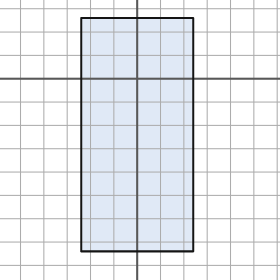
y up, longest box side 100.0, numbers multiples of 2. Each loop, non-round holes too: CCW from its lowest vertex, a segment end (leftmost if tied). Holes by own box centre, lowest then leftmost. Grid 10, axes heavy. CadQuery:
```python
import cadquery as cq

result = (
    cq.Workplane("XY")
    .moveTo(-24.0, -74.0)
    .lineTo(24.0, -74.0)
    .lineTo(24.0, 26.0)
    .lineTo(-24.0, 26.0)
    .close()
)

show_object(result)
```